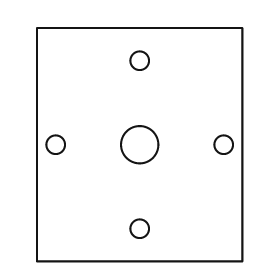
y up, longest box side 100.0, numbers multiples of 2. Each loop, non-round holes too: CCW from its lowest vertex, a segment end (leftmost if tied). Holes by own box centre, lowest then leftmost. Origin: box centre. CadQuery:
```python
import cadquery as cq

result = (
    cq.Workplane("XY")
    .moveTo(-44.0, -50.0)
    .lineTo(44.0, -50.0)
    .lineTo(44.0, 50.0)
    .lineTo(-44.0, 50.0)
    .close()
    .moveTo(0.0, -36.0)
    .circle(4.0)
    .moveTo(-36.0, 0.0)
    .circle(4.0)
    .moveTo(0.0, 0.0)
    .circle(8.0)
    .moveTo(36.0, 0.0)
    .circle(4.0)
    .moveTo(0.0, 36.0)
    .circle(4.0)
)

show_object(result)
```